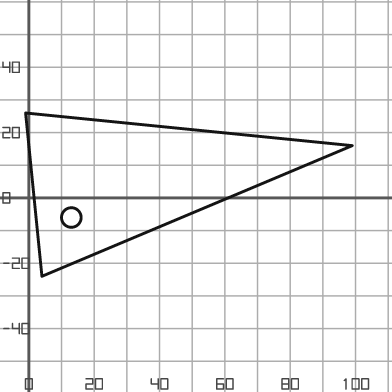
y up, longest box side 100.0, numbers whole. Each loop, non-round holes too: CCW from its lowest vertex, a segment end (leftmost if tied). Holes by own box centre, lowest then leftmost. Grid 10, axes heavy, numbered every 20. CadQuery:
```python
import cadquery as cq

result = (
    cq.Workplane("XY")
    .moveTo(4.0, -24.0)
    .lineTo(99.0, 16.0)
    .lineTo(-1.0, 26.0)
    .close()
    .moveTo(13.0, -6.0)
    .circle(3.0)
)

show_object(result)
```